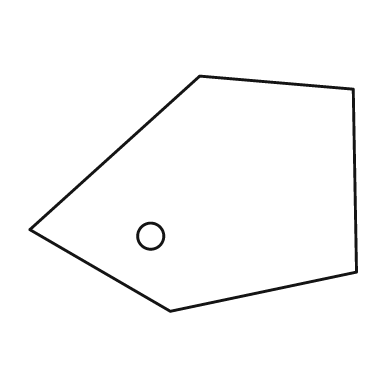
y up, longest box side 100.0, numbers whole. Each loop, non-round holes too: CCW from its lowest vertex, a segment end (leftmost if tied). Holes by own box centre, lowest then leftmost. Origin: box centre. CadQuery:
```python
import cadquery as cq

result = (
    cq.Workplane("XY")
    .moveTo(-7.0, -36.0)
    .lineTo(50.0, -24.0)
    .lineTo(49.0, 32.0)
    .lineTo(2.0, 36.0)
    .lineTo(-50.0, -11.0)
    .close()
    .moveTo(-13.0, -13.0)
    .circle(4.0)
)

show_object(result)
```